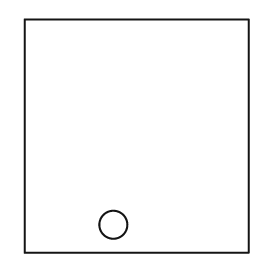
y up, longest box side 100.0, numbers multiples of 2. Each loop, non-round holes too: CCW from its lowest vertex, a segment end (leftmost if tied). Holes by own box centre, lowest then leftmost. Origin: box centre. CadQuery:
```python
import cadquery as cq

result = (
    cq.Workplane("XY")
    .moveTo(-48.0, -50.0)
    .lineTo(48.0, -50.0)
    .lineTo(48.0, 50.0)
    .lineTo(-48.0, 50.0)
    .close()
    .moveTo(-10.0, -38.0)
    .circle(6.0)
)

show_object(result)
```